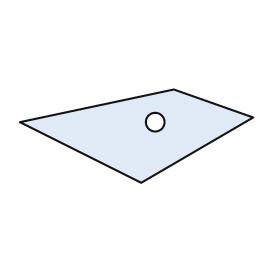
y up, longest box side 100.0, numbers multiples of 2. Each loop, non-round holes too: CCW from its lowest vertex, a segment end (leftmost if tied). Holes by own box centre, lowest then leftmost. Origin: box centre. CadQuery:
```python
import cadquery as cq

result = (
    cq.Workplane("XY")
    .moveTo(2.0, -20.0)
    .lineTo(50.0, 8.0)
    .lineTo(16.0, 20.0)
    .lineTo(-50.0, 6.0)
    .close()
    .moveTo(8.0, 6.0)
    .circle(4.0)
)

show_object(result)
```